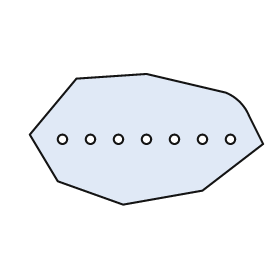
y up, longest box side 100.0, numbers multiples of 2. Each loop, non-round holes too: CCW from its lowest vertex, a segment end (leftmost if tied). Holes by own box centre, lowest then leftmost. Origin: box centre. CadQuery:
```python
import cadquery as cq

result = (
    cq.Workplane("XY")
    .moveTo(-10.0, -28.0)
    .lineTo(24.0, -22.0)
    .lineTo(50.0, -2.0)
    .lineTo(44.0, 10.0)
    .threePointArc((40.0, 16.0), (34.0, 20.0))
    .lineTo(0.0, 28.0)
    .lineTo(-30.0, 26.0)
    .lineTo(-50.0, 2.0)
    .lineTo(-38.0, -18.0)
    .close()
    .moveTo(-36.0, 0.0)
    .circle(2.0)
    .moveTo(-24.0, 0.0)
    .circle(2.0)
    .moveTo(-12.0, 0.0)
    .circle(2.0)
    .moveTo(0.0, 0.0)
    .circle(2.0)
    .moveTo(12.0, 0.0)
    .circle(2.0)
    .moveTo(24.0, 0.0)
    .circle(2.0)
    .moveTo(36.0, 0.0)
    .circle(2.0)
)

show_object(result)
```